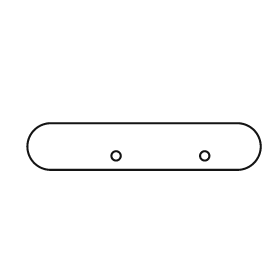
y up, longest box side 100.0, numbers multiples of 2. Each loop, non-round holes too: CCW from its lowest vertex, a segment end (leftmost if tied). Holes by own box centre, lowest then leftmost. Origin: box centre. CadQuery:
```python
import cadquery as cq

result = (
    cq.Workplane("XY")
    .moveTo(-40.0, -10.0)
    .lineTo(40.0, -10.0)
    .threePointArc((50.0, 0.0), (40.0, 10.0))
    .lineTo(-40.0, 10.0)
    .threePointArc((-50.0, 0.0), (-40.0, -10.0))
    .close()
    .moveTo(-12.0, -4.0)
    .circle(2.0)
    .moveTo(26.0, -4.0)
    .circle(2.0)
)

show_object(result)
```